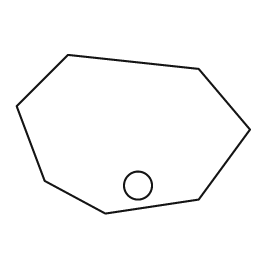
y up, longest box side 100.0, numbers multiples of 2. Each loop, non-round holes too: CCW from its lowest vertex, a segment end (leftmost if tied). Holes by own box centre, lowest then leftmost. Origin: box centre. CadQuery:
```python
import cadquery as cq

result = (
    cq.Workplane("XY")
    .moveTo(-12.0, -34.0)
    .lineTo(28.0, -28.0)
    .lineTo(50.0, 2.0)
    .lineTo(28.0, 28.0)
    .lineTo(-28.0, 34.0)
    .lineTo(-50.0, 12.0)
    .lineTo(-38.0, -20.0)
    .close()
    .moveTo(2.0, -22.0)
    .circle(6.0)
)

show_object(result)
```